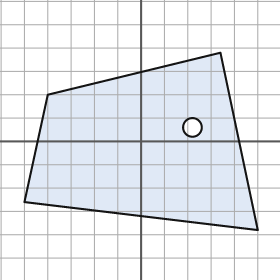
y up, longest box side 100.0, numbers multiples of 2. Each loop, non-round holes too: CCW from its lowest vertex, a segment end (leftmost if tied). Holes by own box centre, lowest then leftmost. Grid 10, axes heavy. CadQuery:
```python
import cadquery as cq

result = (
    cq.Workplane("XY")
    .moveTo(50.0, -38.0)
    .lineTo(34.0, 38.0)
    .lineTo(-40.0, 20.0)
    .lineTo(-50.0, -26.0)
    .close()
    .moveTo(22.0, 6.0)
    .circle(4.0)
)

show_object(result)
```